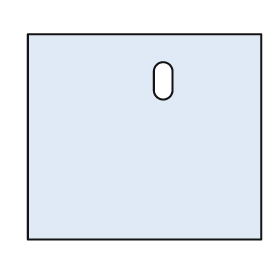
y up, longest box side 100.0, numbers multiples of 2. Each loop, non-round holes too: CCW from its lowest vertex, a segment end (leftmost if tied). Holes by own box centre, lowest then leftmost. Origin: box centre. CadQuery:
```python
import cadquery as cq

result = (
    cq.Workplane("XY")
    .moveTo(-50.0, -44.0)
    .lineTo(50.0, -44.0)
    .lineTo(50.0, 44.0)
    .lineTo(-50.0, 44.0)
    .close()
    .moveTo(4.0, 20.0)
    .threePointArc((8.0, 16.0), (12.0, 20.0))
    .lineTo(12.0, 28.0)
    .threePointArc((8.0, 32.0), (4.0, 28.0))
    .close()
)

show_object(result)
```